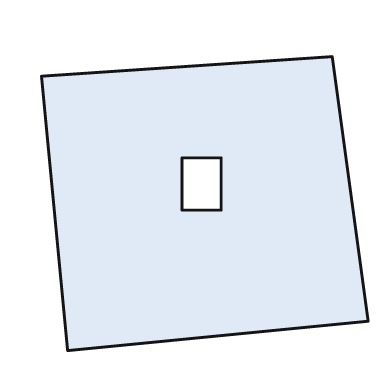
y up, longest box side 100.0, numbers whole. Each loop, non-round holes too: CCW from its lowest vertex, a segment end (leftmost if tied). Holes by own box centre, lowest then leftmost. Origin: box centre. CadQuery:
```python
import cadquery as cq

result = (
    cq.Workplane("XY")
    .moveTo(-42.0, -45.0)
    .lineTo(50.0, -36.0)
    .lineTo(39.0, 45.0)
    .lineTo(-50.0, 39.0)
    .close()
    .moveTo(-7.0, -2.0)
    .lineTo(5.0, -2.0)
    .lineTo(5.0, 14.0)
    .lineTo(-7.0, 14.0)
    .close()
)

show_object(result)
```